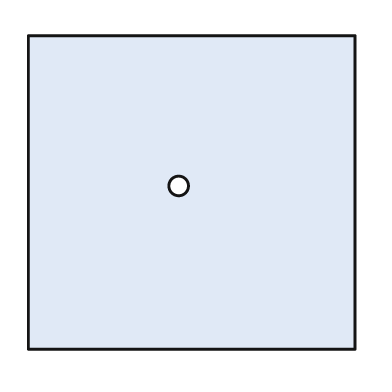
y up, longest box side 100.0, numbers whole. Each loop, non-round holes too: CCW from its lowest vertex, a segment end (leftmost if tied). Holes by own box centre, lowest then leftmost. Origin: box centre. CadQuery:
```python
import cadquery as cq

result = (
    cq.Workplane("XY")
    .moveTo(-50.0, -48.0)
    .lineTo(50.0, -48.0)
    .lineTo(50.0, 48.0)
    .lineTo(-50.0, 48.0)
    .close()
    .moveTo(-4.0, 2.0)
    .circle(3.0)
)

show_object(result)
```